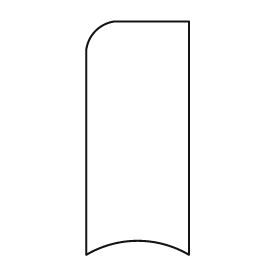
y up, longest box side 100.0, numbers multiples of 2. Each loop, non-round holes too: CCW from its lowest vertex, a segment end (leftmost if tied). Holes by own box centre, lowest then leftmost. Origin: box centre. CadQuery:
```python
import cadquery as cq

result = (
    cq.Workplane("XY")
    .moveTo(-22.0, -50.0)
    .threePointArc((0.0, -44.0), (22.0, -50.0))
    .lineTo(22.0, 50.0)
    .lineTo(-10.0, 50.0)
    .threePointArc((-18.0, 46.0), (-22.0, 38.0))
    .close()
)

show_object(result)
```